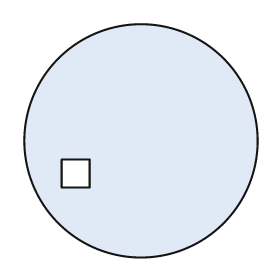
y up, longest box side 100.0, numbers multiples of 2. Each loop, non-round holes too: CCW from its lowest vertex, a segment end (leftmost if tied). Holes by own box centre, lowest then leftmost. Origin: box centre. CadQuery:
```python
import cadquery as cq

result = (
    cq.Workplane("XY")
    .moveTo(0.0, 0.0)
    .circle(50.0)
    .moveTo(-34.0, -20.0)
    .lineTo(-22.0, -20.0)
    .lineTo(-22.0, -8.0)
    .lineTo(-34.0, -8.0)
    .close()
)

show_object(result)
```